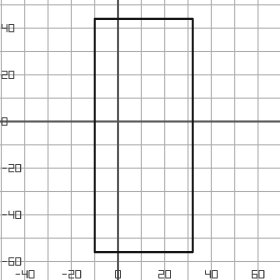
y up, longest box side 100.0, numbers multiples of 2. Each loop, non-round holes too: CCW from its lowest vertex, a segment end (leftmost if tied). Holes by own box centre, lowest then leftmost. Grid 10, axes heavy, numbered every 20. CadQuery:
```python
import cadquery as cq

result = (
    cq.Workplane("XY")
    .moveTo(-10.0, -56.0)
    .lineTo(32.0, -56.0)
    .lineTo(32.0, 44.0)
    .lineTo(-10.0, 44.0)
    .close()
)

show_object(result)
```